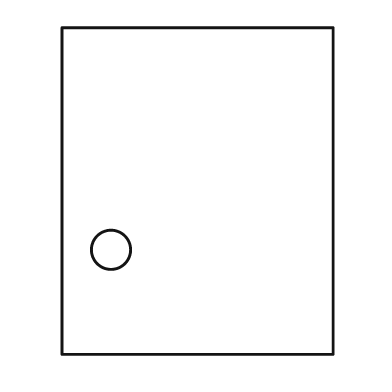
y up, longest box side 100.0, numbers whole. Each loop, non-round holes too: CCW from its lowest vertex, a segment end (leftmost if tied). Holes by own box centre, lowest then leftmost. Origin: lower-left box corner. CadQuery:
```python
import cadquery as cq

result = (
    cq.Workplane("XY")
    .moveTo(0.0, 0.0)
    .lineTo(83.0, 0.0)
    .lineTo(83.0, 100.0)
    .lineTo(0.0, 100.0)
    .close()
    .moveTo(15.0, 32.0)
    .circle(6.0)
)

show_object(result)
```